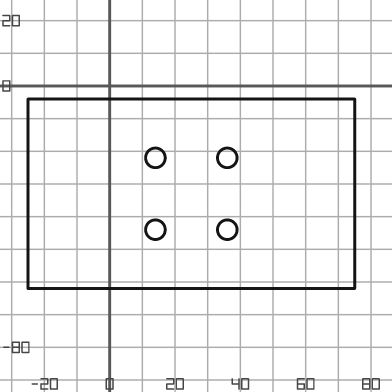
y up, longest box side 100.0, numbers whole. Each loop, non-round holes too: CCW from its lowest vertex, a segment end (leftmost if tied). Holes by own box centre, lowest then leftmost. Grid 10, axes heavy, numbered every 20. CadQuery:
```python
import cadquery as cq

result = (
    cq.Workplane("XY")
    .moveTo(-25.0, -62.0)
    .lineTo(75.0, -62.0)
    .lineTo(75.0, -4.0)
    .lineTo(-25.0, -4.0)
    .close()
    .moveTo(14.0, -44.0)
    .circle(3.0)
    .moveTo(36.0, -44.0)
    .circle(3.0)
    .moveTo(14.0, -22.0)
    .circle(3.0)
    .moveTo(36.0, -22.0)
    .circle(3.0)
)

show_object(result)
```